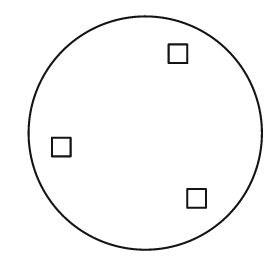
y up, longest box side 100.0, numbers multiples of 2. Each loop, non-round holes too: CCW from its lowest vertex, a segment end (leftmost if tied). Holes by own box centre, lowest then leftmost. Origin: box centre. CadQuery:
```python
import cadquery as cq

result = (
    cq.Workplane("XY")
    .moveTo(0.0, 0.0)
    .circle(50.0)
    .moveTo(18.0, -32.0)
    .lineTo(26.0, -32.0)
    .lineTo(26.0, -24.0)
    .lineTo(18.0, -24.0)
    .close()
    .moveTo(-40.0, -10.0)
    .lineTo(-32.0, -10.0)
    .lineTo(-32.0, -2.0)
    .lineTo(-40.0, -2.0)
    .close()
    .moveTo(10.0, 30.0)
    .lineTo(18.0, 30.0)
    .lineTo(18.0, 38.0)
    .lineTo(10.0, 38.0)
    .close()
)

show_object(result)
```